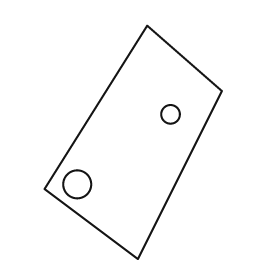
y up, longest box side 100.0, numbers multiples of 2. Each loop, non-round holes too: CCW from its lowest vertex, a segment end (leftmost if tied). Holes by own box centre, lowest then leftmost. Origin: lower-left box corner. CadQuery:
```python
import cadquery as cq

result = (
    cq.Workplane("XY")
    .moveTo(40.0, 0.0)
    .lineTo(76.0, 72.0)
    .lineTo(44.0, 100.0)
    .lineTo(0.0, 30.0)
    .close()
    .moveTo(14.0, 32.0)
    .circle(6.0)
    .moveTo(54.0, 62.0)
    .circle(4.0)
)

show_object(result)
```